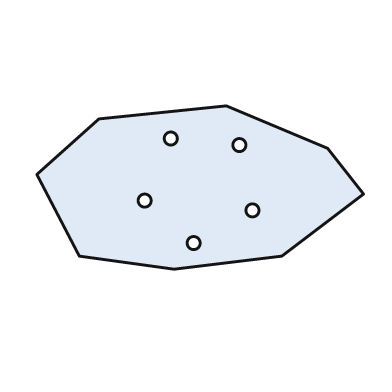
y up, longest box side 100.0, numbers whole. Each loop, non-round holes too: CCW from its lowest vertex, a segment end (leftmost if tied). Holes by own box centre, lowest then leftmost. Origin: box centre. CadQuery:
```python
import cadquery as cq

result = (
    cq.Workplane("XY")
    .moveTo(-8.0, -25.0)
    .lineTo(25.0, -21.0)
    .lineTo(50.0, -2.0)
    .lineTo(39.0, 12.0)
    .lineTo(8.0, 25.0)
    .lineTo(-31.0, 21.0)
    .lineTo(-50.0, 4.0)
    .lineTo(-37.0, -21.0)
    .close()
    .moveTo(-2.0, -17.0)
    .circle(2.0)
    .moveTo(16.0, -7.0)
    .circle(2.0)
    .moveTo(-17.0, -4.0)
    .circle(2.0)
    .moveTo(12.0, 13.0)
    .circle(2.0)
    .moveTo(-9.0, 15.0)
    .circle(2.0)
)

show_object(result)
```